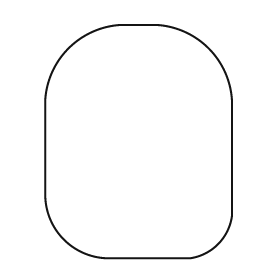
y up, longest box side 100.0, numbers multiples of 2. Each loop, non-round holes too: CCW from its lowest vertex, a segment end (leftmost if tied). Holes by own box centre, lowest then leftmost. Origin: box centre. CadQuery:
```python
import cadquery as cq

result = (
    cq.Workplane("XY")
    .moveTo(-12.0, -50.0)
    .lineTo(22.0, -50.0)
    .threePointArc((34.0, -44.0), (40.0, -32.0))
    .lineTo(40.0, 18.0)
    .threePointArc((30.0, 40.0), (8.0, 50.0))
    .lineTo(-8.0, 50.0)
    .threePointArc((-30.0, 40.0), (-40.0, 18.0))
    .lineTo(-40.0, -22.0)
    .threePointArc((-32.0, -42.0), (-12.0, -50.0))
    .close()
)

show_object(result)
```